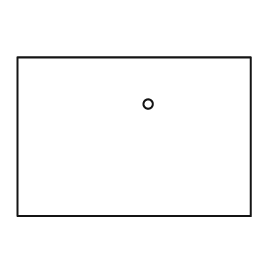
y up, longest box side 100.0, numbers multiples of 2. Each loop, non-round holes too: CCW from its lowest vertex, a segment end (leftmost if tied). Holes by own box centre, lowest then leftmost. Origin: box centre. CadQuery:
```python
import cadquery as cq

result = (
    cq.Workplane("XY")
    .moveTo(-50.0, -34.0)
    .lineTo(50.0, -34.0)
    .lineTo(50.0, 34.0)
    .lineTo(-50.0, 34.0)
    .close()
    .moveTo(6.0, 14.0)
    .circle(2.0)
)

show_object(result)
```